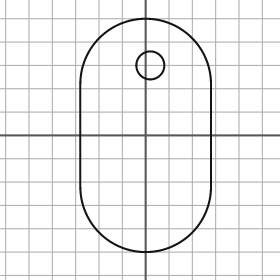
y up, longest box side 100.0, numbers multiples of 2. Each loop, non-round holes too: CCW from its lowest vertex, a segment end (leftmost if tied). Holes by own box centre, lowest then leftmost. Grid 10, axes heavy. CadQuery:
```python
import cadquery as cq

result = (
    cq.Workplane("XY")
    .moveTo(-28.0, -22.0)
    .threePointArc((0.0, -50.0), (28.0, -22.0))
    .lineTo(28.0, 22.0)
    .threePointArc((0.0, 50.0), (-28.0, 22.0))
    .close()
    .moveTo(2.0, 30.0)
    .circle(6.0)
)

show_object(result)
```